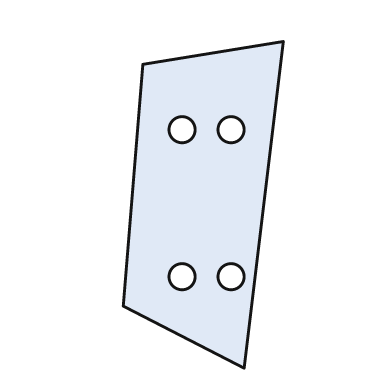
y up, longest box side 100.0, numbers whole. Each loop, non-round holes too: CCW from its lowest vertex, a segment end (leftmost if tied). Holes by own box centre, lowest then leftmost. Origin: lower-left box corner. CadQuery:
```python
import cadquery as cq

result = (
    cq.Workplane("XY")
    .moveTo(37.0, 0.0)
    .lineTo(49.0, 100.0)
    .lineTo(6.0, 93.0)
    .lineTo(0.0, 19.0)
    .close()
    .moveTo(18.0, 28.0)
    .circle(4.0)
    .moveTo(33.0, 28.0)
    .circle(4.0)
    .moveTo(18.0, 73.0)
    .circle(4.0)
    .moveTo(33.0, 73.0)
    .circle(4.0)
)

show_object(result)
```